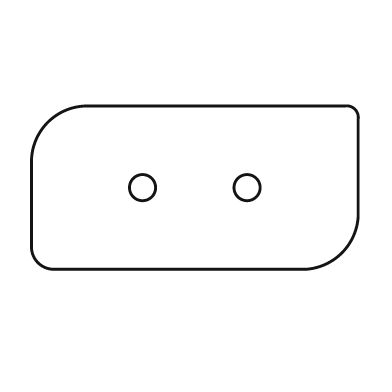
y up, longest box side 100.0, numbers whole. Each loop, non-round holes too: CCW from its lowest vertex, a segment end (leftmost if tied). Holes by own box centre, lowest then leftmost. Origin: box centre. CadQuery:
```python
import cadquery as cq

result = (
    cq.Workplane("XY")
    .moveTo(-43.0, -25.0)
    .lineTo(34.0, -25.0)
    .threePointArc((45.0, -20.0), (50.0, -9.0))
    .lineTo(50.0, 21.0)
    .threePointArc((49.0, 24.0), (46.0, 25.0))
    .lineTo(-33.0, 25.0)
    .threePointArc((-45.0, 20.0), (-50.0, 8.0))
    .lineTo(-50.0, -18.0)
    .threePointArc((-48.0, -23.0), (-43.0, -25.0))
    .close()
    .moveTo(-16.0, 0.0)
    .circle(4.0)
    .moveTo(16.0, 0.0)
    .circle(4.0)
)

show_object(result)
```